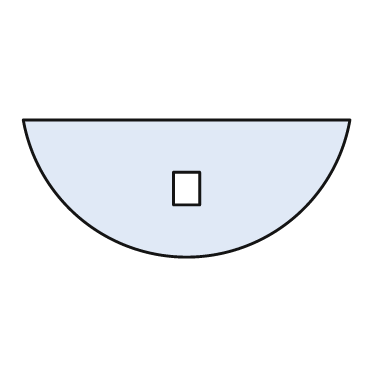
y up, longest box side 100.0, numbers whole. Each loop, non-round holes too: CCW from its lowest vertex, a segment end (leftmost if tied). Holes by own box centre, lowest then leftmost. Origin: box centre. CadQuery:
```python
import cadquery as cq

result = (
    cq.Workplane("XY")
    .moveTo(-50.0, 21.0)
    .threePointArc((0.0, -21.0), (50.0, 21.0))
    .close()
    .moveTo(-4.0, -5.0)
    .lineTo(4.0, -5.0)
    .lineTo(4.0, 5.0)
    .lineTo(-4.0, 5.0)
    .close()
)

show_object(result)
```